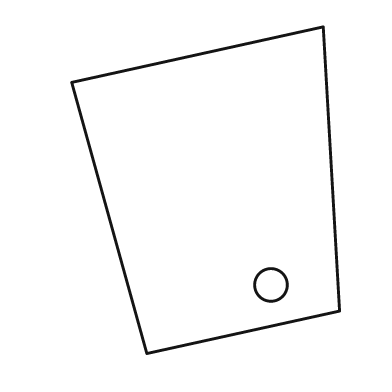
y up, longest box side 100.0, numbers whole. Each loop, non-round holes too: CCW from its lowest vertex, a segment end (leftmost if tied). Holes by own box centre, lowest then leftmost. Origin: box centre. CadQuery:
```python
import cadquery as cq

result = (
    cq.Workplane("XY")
    .moveTo(-18.0, -50.0)
    .lineTo(41.0, -37.0)
    .lineTo(36.0, 50.0)
    .lineTo(-41.0, 33.0)
    .close()
    .moveTo(20.0, -29.0)
    .circle(5.0)
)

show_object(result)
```